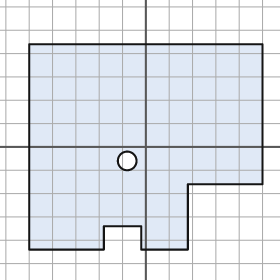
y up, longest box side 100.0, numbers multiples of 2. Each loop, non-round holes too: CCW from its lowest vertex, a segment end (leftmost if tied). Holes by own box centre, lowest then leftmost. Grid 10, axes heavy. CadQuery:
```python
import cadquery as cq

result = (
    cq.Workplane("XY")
    .moveTo(-50.0, -44.0)
    .lineTo(-18.0, -44.0)
    .lineTo(-18.0, -34.0)
    .lineTo(-2.0, -34.0)
    .lineTo(-2.0, -44.0)
    .lineTo(18.0, -44.0)
    .lineTo(18.0, -16.0)
    .lineTo(50.0, -16.0)
    .lineTo(50.0, 44.0)
    .lineTo(-50.0, 44.0)
    .close()
    .moveTo(-8.0, -6.0)
    .circle(4.0)
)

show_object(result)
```